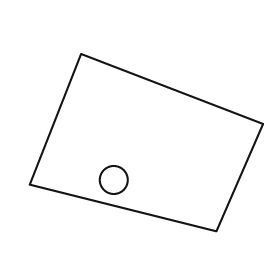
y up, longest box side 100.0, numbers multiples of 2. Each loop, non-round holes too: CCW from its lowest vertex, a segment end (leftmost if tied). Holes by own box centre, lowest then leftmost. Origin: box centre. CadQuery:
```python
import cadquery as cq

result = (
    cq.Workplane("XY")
    .moveTo(30.0, -38.0)
    .lineTo(50.0, 8.0)
    .lineTo(-28.0, 38.0)
    .lineTo(-50.0, -18.0)
    .close()
    .moveTo(-14.0, -16.0)
    .circle(6.0)
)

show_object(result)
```